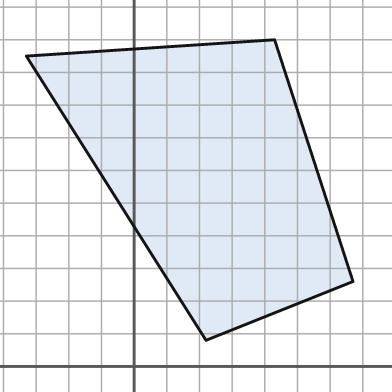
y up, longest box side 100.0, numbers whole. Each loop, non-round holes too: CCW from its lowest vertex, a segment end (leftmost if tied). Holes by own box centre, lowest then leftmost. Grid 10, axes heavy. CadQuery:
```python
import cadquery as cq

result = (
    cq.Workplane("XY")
    .moveTo(22.0, 8.0)
    .lineTo(67.0, 26.0)
    .lineTo(43.0, 100.0)
    .lineTo(-33.0, 95.0)
    .close()
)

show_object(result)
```